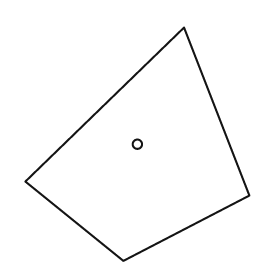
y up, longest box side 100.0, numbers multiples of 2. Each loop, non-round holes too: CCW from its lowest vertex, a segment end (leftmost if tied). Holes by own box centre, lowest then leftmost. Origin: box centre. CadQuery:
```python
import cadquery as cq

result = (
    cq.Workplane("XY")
    .moveTo(-6.0, -50.0)
    .lineTo(48.0, -22.0)
    .lineTo(20.0, 50.0)
    .lineTo(-48.0, -16.0)
    .close()
    .moveTo(0.0, 0.0)
    .circle(2.0)
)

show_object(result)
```